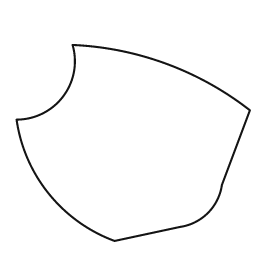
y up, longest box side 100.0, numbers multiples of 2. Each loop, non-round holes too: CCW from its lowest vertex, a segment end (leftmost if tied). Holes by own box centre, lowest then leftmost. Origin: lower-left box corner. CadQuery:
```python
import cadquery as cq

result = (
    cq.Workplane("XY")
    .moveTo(42.0, 0.0)
    .lineTo(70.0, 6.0)
    .threePointArc((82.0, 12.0), (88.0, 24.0))
    .lineTo(100.0, 56.0)
    .threePointArc((64.0, 76.0), (24.0, 84.0))
    .threePointArc((20.0, 62.0), (0.0, 52.0))
    .threePointArc((14.0, 20.0), (42.0, 0.0))
    .close()
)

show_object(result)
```